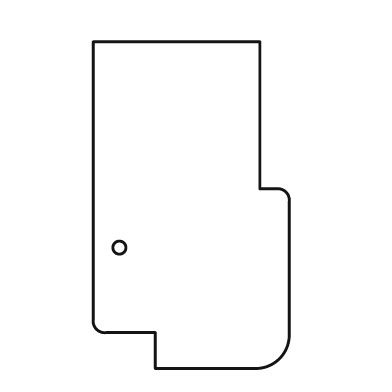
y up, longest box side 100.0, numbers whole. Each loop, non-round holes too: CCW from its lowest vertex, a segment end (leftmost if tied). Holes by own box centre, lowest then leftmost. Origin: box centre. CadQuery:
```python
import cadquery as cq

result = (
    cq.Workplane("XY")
    .moveTo(-11.0, -50.0)
    .lineTo(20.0, -50.0)
    .threePointArc((27.0, -47.0), (30.0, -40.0))
    .lineTo(30.0, 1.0)
    .threePointArc((29.0, 4.0), (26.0, 5.0))
    .lineTo(21.0, 5.0)
    .lineTo(21.0, 50.0)
    .lineTo(-30.0, 50.0)
    .lineTo(-30.0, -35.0)
    .threePointArc((-29.0, -38.0), (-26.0, -39.0))
    .lineTo(-11.0, -39.0)
    .close()
    .moveTo(-22.0, -13.0)
    .circle(2.0)
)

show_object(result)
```